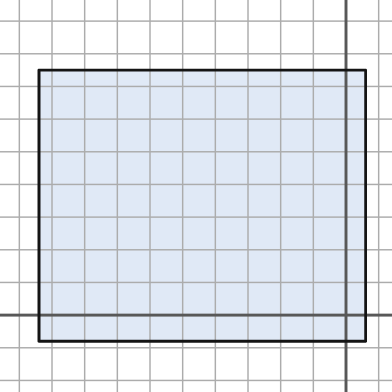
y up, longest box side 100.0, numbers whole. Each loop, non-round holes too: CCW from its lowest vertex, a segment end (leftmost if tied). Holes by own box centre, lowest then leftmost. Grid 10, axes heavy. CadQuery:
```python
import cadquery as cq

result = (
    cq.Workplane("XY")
    .moveTo(-94.0, -8.0)
    .lineTo(6.0, -8.0)
    .lineTo(6.0, 75.0)
    .lineTo(-94.0, 75.0)
    .close()
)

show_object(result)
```